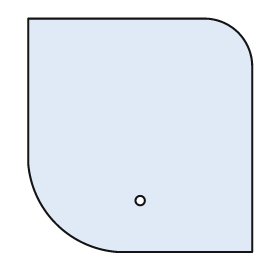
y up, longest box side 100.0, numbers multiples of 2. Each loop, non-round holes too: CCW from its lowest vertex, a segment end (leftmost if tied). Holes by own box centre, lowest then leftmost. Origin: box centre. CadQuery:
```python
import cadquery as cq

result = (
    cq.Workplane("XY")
    .moveTo(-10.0, -50.0)
    .lineTo(48.0, -50.0)
    .lineTo(48.0, 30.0)
    .threePointArc((42.0, 44.0), (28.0, 50.0))
    .lineTo(-48.0, 50.0)
    .lineTo(-48.0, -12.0)
    .threePointArc((-36.0, -38.0), (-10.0, -50.0))
    .close()
    .moveTo(0.0, -28.0)
    .circle(2.0)
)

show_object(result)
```